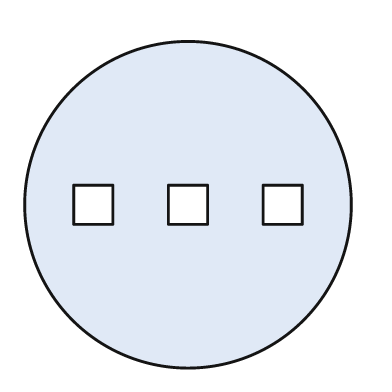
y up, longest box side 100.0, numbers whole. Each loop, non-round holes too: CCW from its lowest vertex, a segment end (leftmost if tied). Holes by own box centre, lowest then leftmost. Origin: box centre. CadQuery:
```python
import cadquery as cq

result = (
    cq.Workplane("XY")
    .moveTo(0.0, 0.0)
    .circle(50.0)
    .moveTo(-35.0, -6.0)
    .lineTo(-23.0, -6.0)
    .lineTo(-23.0, 6.0)
    .lineTo(-35.0, 6.0)
    .close()
    .moveTo(-6.0, -6.0)
    .lineTo(6.0, -6.0)
    .lineTo(6.0, 6.0)
    .lineTo(-6.0, 6.0)
    .close()
    .moveTo(23.0, -6.0)
    .lineTo(35.0, -6.0)
    .lineTo(35.0, 6.0)
    .lineTo(23.0, 6.0)
    .close()
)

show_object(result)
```